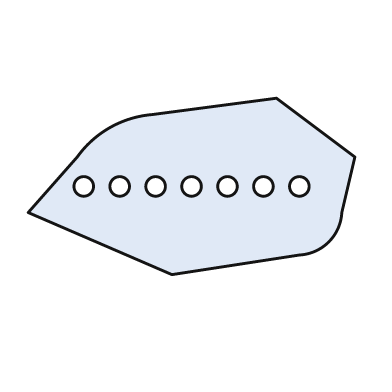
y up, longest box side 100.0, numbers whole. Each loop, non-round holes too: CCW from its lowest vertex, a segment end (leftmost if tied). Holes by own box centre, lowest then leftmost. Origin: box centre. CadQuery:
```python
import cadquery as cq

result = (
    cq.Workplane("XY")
    .moveTo(-6.0, -27.0)
    .lineTo(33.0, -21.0)
    .threePointArc((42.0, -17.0), (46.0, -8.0))
    .lineTo(50.0, 9.0)
    .lineTo(26.0, 27.0)
    .lineTo(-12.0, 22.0)
    .threePointArc((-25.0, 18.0), (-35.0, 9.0))
    .lineTo(-50.0, -8.0)
    .close()
    .moveTo(-33.0, 0.0)
    .circle(3.0)
    .moveTo(-22.0, 0.0)
    .circle(3.0)
    .moveTo(-11.0, 0.0)
    .circle(3.0)
    .moveTo(0.0, 0.0)
    .circle(3.0)
    .moveTo(11.0, 0.0)
    .circle(3.0)
    .moveTo(22.0, 0.0)
    .circle(3.0)
    .moveTo(33.0, 0.0)
    .circle(3.0)
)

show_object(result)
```